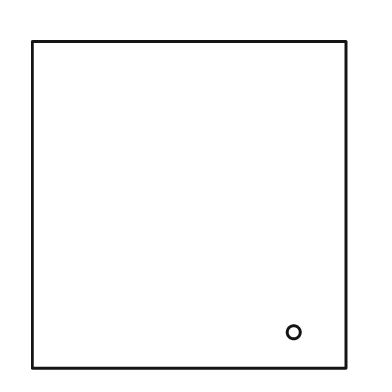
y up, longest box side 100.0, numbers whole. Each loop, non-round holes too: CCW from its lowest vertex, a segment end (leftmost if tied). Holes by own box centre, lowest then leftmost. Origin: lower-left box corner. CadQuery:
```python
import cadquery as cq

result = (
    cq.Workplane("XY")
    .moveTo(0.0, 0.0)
    .lineTo(96.0, 0.0)
    .lineTo(96.0, 100.0)
    .lineTo(0.0, 100.0)
    .close()
    .moveTo(80.0, 11.0)
    .circle(2.0)
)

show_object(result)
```